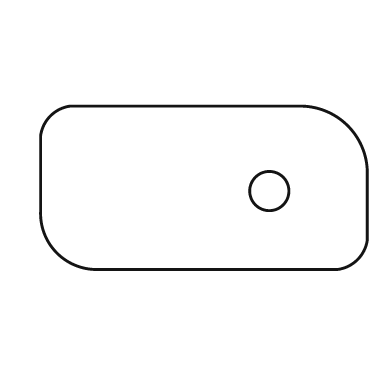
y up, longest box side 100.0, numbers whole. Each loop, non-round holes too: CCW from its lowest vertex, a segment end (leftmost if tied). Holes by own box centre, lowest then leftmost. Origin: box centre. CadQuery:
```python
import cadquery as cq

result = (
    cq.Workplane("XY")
    .moveTo(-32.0, -25.0)
    .lineTo(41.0, -25.0)
    .threePointArc((47.0, -22.0), (50.0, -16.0))
    .lineTo(50.0, 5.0)
    .threePointArc((44.0, 19.0), (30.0, 25.0))
    .lineTo(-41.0, 25.0)
    .threePointArc((-47.0, 22.0), (-50.0, 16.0))
    .lineTo(-50.0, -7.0)
    .threePointArc((-45.0, -20.0), (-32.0, -25.0))
    .close()
    .moveTo(20.0, -1.0)
    .circle(6.0)
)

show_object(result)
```